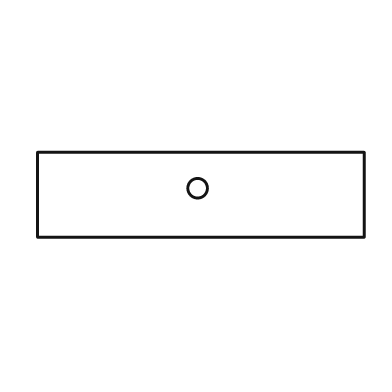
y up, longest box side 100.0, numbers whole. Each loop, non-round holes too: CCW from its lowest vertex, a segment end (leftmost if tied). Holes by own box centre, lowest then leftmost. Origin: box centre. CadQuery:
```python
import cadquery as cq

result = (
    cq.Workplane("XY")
    .moveTo(-50.0, -13.0)
    .lineTo(50.0, -13.0)
    .lineTo(50.0, 13.0)
    .lineTo(-50.0, 13.0)
    .close()
    .moveTo(-1.0, 2.0)
    .circle(3.0)
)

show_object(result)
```